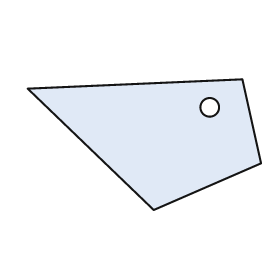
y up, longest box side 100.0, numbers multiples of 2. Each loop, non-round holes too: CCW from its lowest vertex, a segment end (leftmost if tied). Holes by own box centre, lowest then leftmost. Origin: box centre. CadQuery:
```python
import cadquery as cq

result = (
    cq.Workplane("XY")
    .moveTo(4.0, -28.0)
    .lineTo(50.0, -8.0)
    .lineTo(42.0, 28.0)
    .lineTo(-50.0, 24.0)
    .close()
    .moveTo(28.0, 16.0)
    .circle(4.0)
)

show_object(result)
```